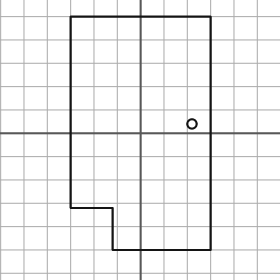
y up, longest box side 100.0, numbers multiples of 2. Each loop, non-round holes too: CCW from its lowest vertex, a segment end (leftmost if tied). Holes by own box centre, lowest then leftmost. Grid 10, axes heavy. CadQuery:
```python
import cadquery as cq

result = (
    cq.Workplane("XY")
    .moveTo(-12.0, -50.0)
    .lineTo(30.0, -50.0)
    .lineTo(30.0, 50.0)
    .lineTo(-30.0, 50.0)
    .lineTo(-30.0, -32.0)
    .lineTo(-12.0, -32.0)
    .close()
    .moveTo(22.0, 4.0)
    .circle(2.0)
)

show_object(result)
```